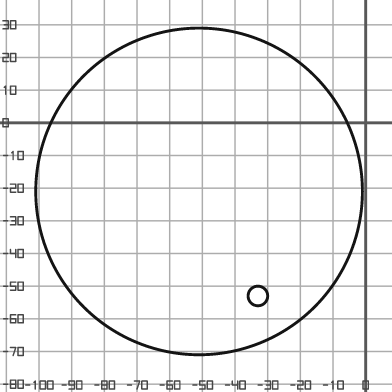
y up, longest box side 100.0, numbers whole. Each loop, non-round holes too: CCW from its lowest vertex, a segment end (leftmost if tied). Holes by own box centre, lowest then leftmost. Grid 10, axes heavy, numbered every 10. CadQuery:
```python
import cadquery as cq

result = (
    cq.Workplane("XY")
    .moveTo(-51.0, -21.0)
    .circle(50.0)
    .moveTo(-33.0, -53.0)
    .circle(3.0)
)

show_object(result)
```